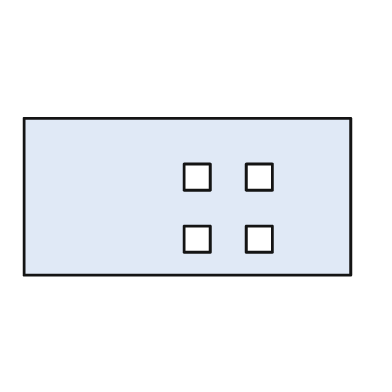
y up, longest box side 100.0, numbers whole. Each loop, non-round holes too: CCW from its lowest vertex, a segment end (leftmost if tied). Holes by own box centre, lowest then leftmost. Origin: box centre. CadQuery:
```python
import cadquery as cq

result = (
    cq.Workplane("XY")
    .moveTo(-50.0, -24.0)
    .lineTo(50.0, -24.0)
    .lineTo(50.0, 24.0)
    .lineTo(-50.0, 24.0)
    .close()
    .moveTo(-1.0, -17.0)
    .lineTo(7.0, -17.0)
    .lineTo(7.0, -9.0)
    .lineTo(-1.0, -9.0)
    .close()
    .moveTo(18.0, -17.0)
    .lineTo(26.0, -17.0)
    .lineTo(26.0, -9.0)
    .lineTo(18.0, -9.0)
    .close()
    .moveTo(-1.0, 2.0)
    .lineTo(7.0, 2.0)
    .lineTo(7.0, 10.0)
    .lineTo(-1.0, 10.0)
    .close()
    .moveTo(18.0, 2.0)
    .lineTo(26.0, 2.0)
    .lineTo(26.0, 10.0)
    .lineTo(18.0, 10.0)
    .close()
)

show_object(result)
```